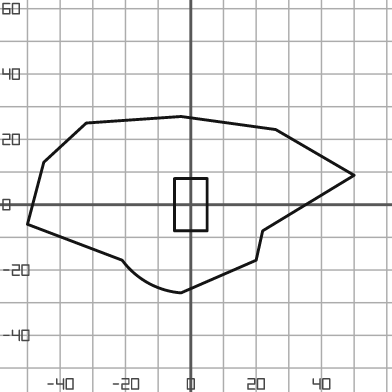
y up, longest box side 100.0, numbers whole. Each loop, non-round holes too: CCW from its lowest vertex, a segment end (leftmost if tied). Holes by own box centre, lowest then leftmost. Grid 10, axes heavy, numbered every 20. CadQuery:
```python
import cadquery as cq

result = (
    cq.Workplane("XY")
    .moveTo(-3.0, -27.0)
    .lineTo(20.0, -17.0)
    .lineTo(22.0, -8.0)
    .lineTo(50.0, 9.0)
    .lineTo(26.0, 23.0)
    .lineTo(-3.0, 27.0)
    .lineTo(-32.0, 25.0)
    .lineTo(-45.0, 13.0)
    .lineTo(-50.0, -6.0)
    .lineTo(-21.0, -17.0)
    .threePointArc((-13.0, -24.0), (-3.0, -27.0))
    .close()
    .moveTo(-5.0, -8.0)
    .lineTo(5.0, -8.0)
    .lineTo(5.0, 8.0)
    .lineTo(-5.0, 8.0)
    .close()
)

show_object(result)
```